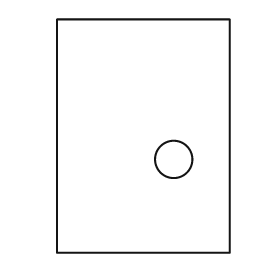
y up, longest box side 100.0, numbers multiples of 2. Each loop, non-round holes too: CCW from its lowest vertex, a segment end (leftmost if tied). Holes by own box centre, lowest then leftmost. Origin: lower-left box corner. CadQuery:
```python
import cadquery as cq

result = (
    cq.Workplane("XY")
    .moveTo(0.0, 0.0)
    .lineTo(74.0, 0.0)
    .lineTo(74.0, 100.0)
    .lineTo(0.0, 100.0)
    .close()
    .moveTo(50.0, 40.0)
    .circle(8.0)
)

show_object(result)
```